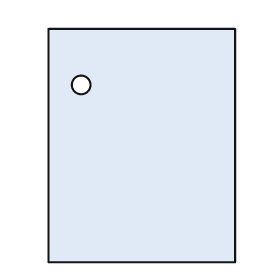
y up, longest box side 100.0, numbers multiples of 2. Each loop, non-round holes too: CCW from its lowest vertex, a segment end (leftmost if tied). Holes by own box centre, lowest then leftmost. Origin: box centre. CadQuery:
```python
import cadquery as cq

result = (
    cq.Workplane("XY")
    .moveTo(-40.0, -50.0)
    .lineTo(40.0, -50.0)
    .lineTo(40.0, 50.0)
    .lineTo(-40.0, 50.0)
    .close()
    .moveTo(-26.0, 26.0)
    .circle(4.0)
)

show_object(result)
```